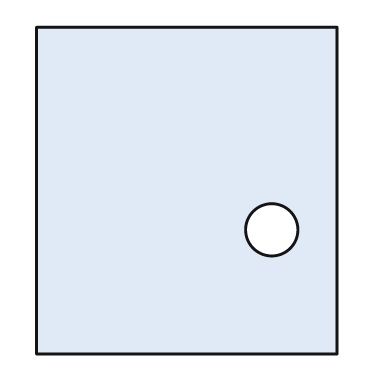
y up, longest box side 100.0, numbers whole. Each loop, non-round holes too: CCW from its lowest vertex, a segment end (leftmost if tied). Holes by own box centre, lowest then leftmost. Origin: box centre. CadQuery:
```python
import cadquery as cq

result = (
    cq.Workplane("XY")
    .moveTo(-46.0, -50.0)
    .lineTo(46.0, -50.0)
    .lineTo(46.0, 50.0)
    .lineTo(-46.0, 50.0)
    .close()
    .moveTo(26.0, -12.0)
    .circle(8.0)
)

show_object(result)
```